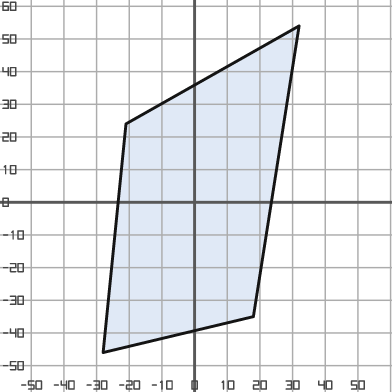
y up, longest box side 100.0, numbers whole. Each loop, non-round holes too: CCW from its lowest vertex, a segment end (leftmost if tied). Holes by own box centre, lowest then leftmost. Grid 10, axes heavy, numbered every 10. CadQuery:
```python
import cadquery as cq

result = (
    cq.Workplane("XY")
    .moveTo(-28.0, -46.0)
    .lineTo(18.0, -35.0)
    .lineTo(32.0, 54.0)
    .lineTo(-21.0, 24.0)
    .close()
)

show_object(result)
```